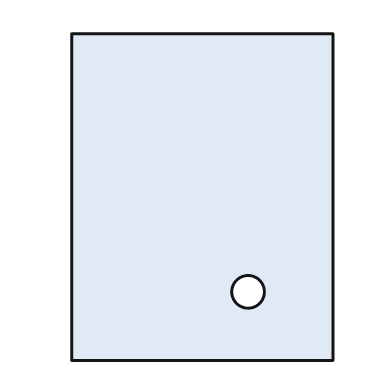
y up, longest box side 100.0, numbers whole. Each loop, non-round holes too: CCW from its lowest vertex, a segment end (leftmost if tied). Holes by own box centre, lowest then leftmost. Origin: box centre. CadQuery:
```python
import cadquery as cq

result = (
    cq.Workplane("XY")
    .moveTo(-40.0, -50.0)
    .lineTo(40.0, -50.0)
    .lineTo(40.0, 50.0)
    .lineTo(-40.0, 50.0)
    .close()
    .moveTo(14.0, -29.0)
    .circle(5.0)
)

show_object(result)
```